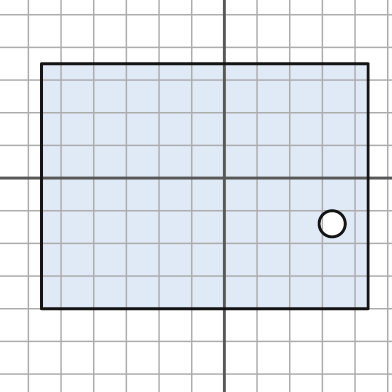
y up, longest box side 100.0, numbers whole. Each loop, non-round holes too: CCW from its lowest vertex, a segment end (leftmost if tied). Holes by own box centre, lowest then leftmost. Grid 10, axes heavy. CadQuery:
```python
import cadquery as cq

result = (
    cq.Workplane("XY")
    .moveTo(-56.0, -40.0)
    .lineTo(44.0, -40.0)
    .lineTo(44.0, 35.0)
    .lineTo(-56.0, 35.0)
    .close()
    .moveTo(33.0, -14.0)
    .circle(4.0)
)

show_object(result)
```